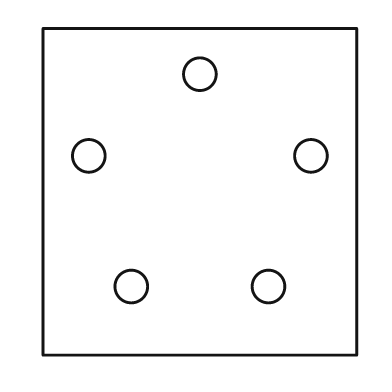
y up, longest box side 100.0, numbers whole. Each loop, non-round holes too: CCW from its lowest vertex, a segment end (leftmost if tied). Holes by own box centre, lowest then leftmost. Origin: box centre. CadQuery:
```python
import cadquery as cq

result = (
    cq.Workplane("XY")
    .moveTo(-48.0, -50.0)
    .lineTo(48.0, -50.0)
    .lineTo(48.0, 50.0)
    .lineTo(-48.0, 50.0)
    .close()
    .moveTo(-21.0, -29.0)
    .circle(5.0)
    .moveTo(21.0, -29.0)
    .circle(5.0)
    .moveTo(-34.0, 11.0)
    .circle(5.0)
    .moveTo(34.0, 11.0)
    .circle(5.0)
    .moveTo(0.0, 36.0)
    .circle(5.0)
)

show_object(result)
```